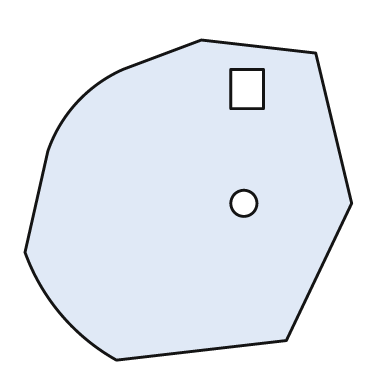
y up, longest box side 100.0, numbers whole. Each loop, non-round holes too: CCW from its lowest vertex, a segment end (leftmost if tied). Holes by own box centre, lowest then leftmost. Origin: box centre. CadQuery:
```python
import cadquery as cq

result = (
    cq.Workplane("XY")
    .moveTo(-22.0, -49.0)
    .lineTo(30.0, -43.0)
    .lineTo(50.0, -1.0)
    .lineTo(39.0, 45.0)
    .lineTo(4.0, 49.0)
    .lineTo(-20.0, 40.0)
    .threePointArc((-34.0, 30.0), (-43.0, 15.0))
    .lineTo(-50.0, -16.0)
    .threePointArc((-39.0, -35.0), (-22.0, -49.0))
    .close()
    .moveTo(17.0, -1.0)
    .circle(4.0)
    .moveTo(13.0, 28.0)
    .lineTo(23.0, 28.0)
    .lineTo(23.0, 40.0)
    .lineTo(13.0, 40.0)
    .close()
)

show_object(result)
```